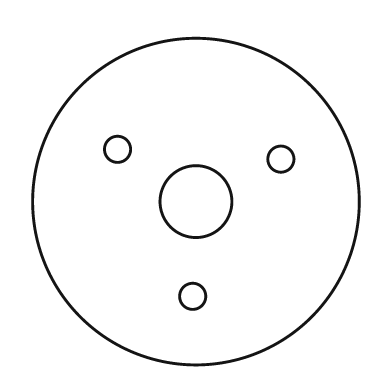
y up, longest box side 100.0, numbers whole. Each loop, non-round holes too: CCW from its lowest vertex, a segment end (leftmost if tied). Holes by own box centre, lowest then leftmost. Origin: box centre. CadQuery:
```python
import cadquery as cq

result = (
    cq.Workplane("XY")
    .moveTo(0.0, 0.0)
    .circle(50.0)
    .moveTo(-1.0, -29.0)
    .circle(4.0)
    .moveTo(0.0, 0.0)
    .circle(11.0)
    .moveTo(26.0, 13.0)
    .circle(4.0)
    .moveTo(-24.0, 16.0)
    .circle(4.0)
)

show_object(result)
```